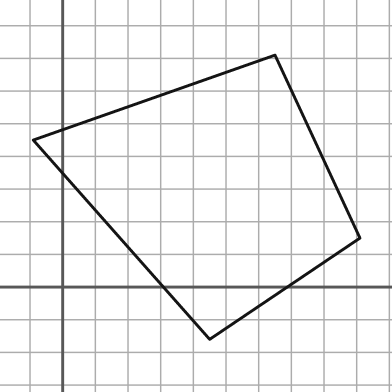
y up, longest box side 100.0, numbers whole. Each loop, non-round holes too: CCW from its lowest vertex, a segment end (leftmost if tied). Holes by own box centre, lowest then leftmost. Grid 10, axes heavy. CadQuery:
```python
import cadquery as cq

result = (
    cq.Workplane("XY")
    .moveTo(45.0, -16.0)
    .lineTo(91.0, 15.0)
    .lineTo(65.0, 71.0)
    .lineTo(-9.0, 45.0)
    .close()
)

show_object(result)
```